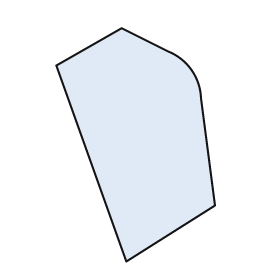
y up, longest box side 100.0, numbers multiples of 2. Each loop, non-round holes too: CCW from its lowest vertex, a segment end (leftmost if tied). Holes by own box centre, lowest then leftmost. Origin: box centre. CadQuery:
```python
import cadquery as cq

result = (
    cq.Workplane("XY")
    .moveTo(-4.0, -50.0)
    .lineTo(34.0, -26.0)
    .lineTo(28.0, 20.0)
    .threePointArc((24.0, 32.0), (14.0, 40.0))
    .lineTo(-6.0, 50.0)
    .lineTo(-34.0, 34.0)
    .close()
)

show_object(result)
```